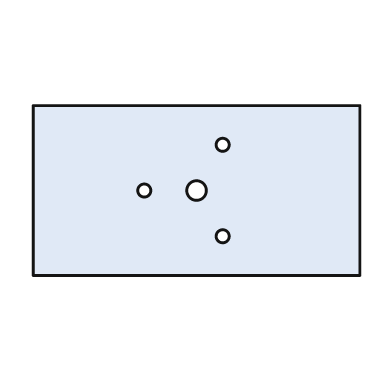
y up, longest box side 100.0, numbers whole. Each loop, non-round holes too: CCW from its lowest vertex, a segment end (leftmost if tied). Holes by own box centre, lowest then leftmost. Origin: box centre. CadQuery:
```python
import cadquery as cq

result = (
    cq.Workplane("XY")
    .moveTo(-50.0, -26.0)
    .lineTo(50.0, -26.0)
    .lineTo(50.0, 26.0)
    .lineTo(-50.0, 26.0)
    .close()
    .moveTo(8.0, -14.0)
    .circle(2.0)
    .moveTo(-16.0, 0.0)
    .circle(2.0)
    .moveTo(0.0, 0.0)
    .circle(3.0)
    .moveTo(8.0, 14.0)
    .circle(2.0)
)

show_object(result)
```